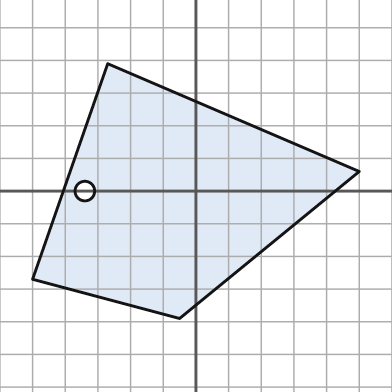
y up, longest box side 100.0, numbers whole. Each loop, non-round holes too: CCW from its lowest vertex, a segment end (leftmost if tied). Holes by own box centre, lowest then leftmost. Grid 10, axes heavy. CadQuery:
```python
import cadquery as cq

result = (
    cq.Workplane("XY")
    .moveTo(-5.0, -39.0)
    .lineTo(50.0, 6.0)
    .lineTo(-27.0, 39.0)
    .lineTo(-50.0, -27.0)
    .close()
    .moveTo(-34.0, 0.0)
    .circle(3.0)
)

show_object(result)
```